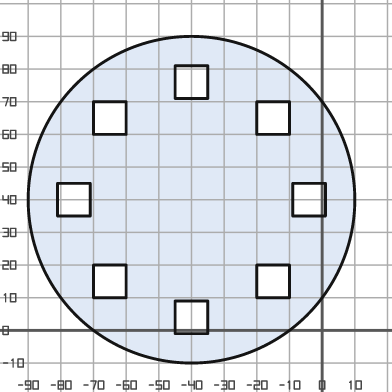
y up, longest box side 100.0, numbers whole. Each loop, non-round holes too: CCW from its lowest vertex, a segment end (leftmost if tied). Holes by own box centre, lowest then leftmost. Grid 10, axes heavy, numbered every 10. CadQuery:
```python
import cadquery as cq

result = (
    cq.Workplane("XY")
    .moveTo(-40.0, 40.0)
    .circle(50.0)
    .moveTo(-45.0, -1.0)
    .lineTo(-35.0, -1.0)
    .lineTo(-35.0, 9.0)
    .lineTo(-45.0, 9.0)
    .close()
    .moveTo(-70.0, 10.0)
    .lineTo(-60.0, 10.0)
    .lineTo(-60.0, 20.0)
    .lineTo(-70.0, 20.0)
    .close()
    .moveTo(-20.0, 10.0)
    .lineTo(-10.0, 10.0)
    .lineTo(-10.0, 20.0)
    .lineTo(-20.0, 20.0)
    .close()
    .moveTo(-81.0, 35.0)
    .lineTo(-71.0, 35.0)
    .lineTo(-71.0, 45.0)
    .lineTo(-81.0, 45.0)
    .close()
    .moveTo(-9.0, 35.0)
    .lineTo(1.0, 35.0)
    .lineTo(1.0, 45.0)
    .lineTo(-9.0, 45.0)
    .close()
    .moveTo(-70.0, 60.0)
    .lineTo(-60.0, 60.0)
    .lineTo(-60.0, 70.0)
    .lineTo(-70.0, 70.0)
    .close()
    .moveTo(-20.0, 60.0)
    .lineTo(-10.0, 60.0)
    .lineTo(-10.0, 70.0)
    .lineTo(-20.0, 70.0)
    .close()
    .moveTo(-45.0, 71.0)
    .lineTo(-35.0, 71.0)
    .lineTo(-35.0, 81.0)
    .lineTo(-45.0, 81.0)
    .close()
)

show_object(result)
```